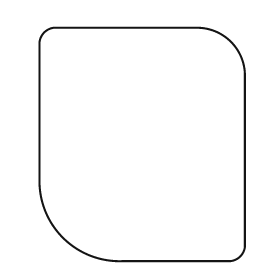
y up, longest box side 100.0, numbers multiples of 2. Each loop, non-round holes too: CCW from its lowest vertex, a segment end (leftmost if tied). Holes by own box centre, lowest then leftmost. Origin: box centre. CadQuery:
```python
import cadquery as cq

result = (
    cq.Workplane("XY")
    .moveTo(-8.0, -50.0)
    .lineTo(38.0, -50.0)
    .threePointArc((42.0, -48.0), (44.0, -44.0))
    .lineTo(44.0, 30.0)
    .threePointArc((38.0, 44.0), (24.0, 50.0))
    .lineTo(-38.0, 50.0)
    .threePointArc((-42.0, 48.0), (-44.0, 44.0))
    .lineTo(-44.0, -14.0)
    .threePointArc((-34.0, -40.0), (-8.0, -50.0))
    .close()
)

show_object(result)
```